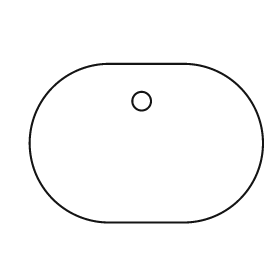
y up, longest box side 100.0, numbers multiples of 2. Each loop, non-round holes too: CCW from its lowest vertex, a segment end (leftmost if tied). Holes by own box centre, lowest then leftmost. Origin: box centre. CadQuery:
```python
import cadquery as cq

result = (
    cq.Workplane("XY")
    .moveTo(-16.0, -34.0)
    .lineTo(16.0, -34.0)
    .threePointArc((50.0, 0.0), (16.0, 34.0))
    .lineTo(-16.0, 34.0)
    .threePointArc((-50.0, 0.0), (-16.0, -34.0))
    .close()
    .moveTo(-2.0, 18.0)
    .circle(4.0)
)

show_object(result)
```